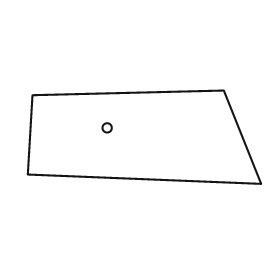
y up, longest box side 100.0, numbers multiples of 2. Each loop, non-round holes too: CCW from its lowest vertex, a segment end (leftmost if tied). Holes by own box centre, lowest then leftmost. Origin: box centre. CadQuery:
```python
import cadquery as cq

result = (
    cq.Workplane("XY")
    .moveTo(50.0, -20.0)
    .lineTo(34.0, 20.0)
    .lineTo(-48.0, 18.0)
    .lineTo(-50.0, -16.0)
    .close()
    .moveTo(-16.0, 4.0)
    .circle(2.0)
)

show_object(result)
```